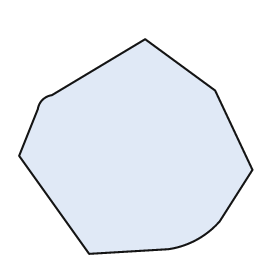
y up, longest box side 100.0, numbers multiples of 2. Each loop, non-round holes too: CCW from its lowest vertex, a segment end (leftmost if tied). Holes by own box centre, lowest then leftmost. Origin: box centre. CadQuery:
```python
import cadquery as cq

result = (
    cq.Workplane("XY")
    .moveTo(-20.0, -46.0)
    .lineTo(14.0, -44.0)
    .threePointArc((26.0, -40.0), (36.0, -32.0))
    .lineTo(50.0, -10.0)
    .lineTo(34.0, 24.0)
    .lineTo(4.0, 46.0)
    .lineTo(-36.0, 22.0)
    .threePointArc((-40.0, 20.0), (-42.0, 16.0))
    .lineTo(-50.0, -4.0)
    .close()
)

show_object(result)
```